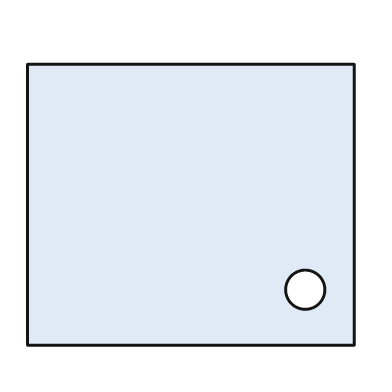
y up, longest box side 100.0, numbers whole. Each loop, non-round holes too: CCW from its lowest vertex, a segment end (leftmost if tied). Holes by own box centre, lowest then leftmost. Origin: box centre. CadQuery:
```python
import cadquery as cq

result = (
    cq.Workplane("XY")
    .moveTo(-50.0, -43.0)
    .lineTo(50.0, -43.0)
    .lineTo(50.0, 43.0)
    .lineTo(-50.0, 43.0)
    .close()
    .moveTo(35.0, -26.0)
    .circle(6.0)
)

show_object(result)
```